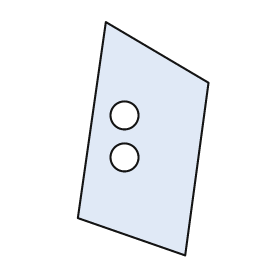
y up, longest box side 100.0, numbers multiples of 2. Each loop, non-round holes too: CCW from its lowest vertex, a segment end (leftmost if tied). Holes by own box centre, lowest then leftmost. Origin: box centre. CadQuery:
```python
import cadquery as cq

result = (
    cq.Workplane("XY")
    .moveTo(18.0, -50.0)
    .lineTo(28.0, 24.0)
    .lineTo(-16.0, 50.0)
    .lineTo(-28.0, -34.0)
    .close()
    .moveTo(-8.0, -8.0)
    .circle(6.0)
    .moveTo(-8.0, 10.0)
    .circle(6.0)
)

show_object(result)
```